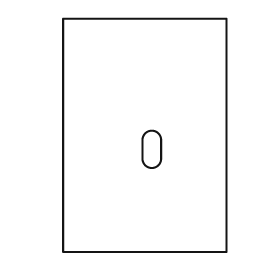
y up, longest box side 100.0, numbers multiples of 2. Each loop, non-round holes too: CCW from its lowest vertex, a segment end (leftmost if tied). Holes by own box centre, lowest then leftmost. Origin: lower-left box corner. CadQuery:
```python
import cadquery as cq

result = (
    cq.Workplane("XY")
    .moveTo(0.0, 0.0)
    .lineTo(70.0, 0.0)
    .lineTo(70.0, 100.0)
    .lineTo(0.0, 100.0)
    .close()
    .moveTo(34.0, 40.0)
    .threePointArc((38.0, 36.0), (42.0, 40.0))
    .lineTo(42.0, 48.0)
    .threePointArc((38.0, 52.0), (34.0, 48.0))
    .close()
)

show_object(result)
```